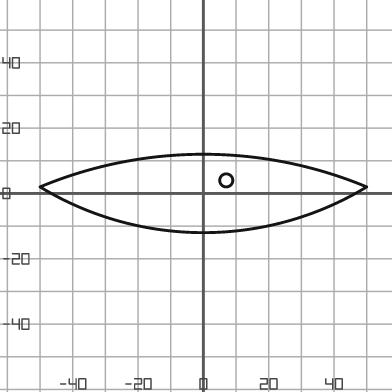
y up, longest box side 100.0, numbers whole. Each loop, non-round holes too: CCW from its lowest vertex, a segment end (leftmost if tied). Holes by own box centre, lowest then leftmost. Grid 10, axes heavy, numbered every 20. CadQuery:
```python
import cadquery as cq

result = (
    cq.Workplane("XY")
    .moveTo(-50.0, 2.0)
    .threePointArc((0.0, -12.0), (50.0, 2.0))
    .threePointArc((0.0, 12.0), (-50.0, 2.0))
    .close()
    .moveTo(7.0, 4.0)
    .circle(2.0)
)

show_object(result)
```